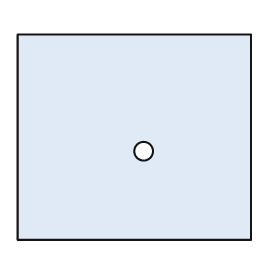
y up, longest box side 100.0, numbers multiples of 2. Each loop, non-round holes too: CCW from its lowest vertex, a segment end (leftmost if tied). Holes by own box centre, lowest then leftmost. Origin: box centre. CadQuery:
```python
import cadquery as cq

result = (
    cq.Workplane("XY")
    .moveTo(-50.0, -44.0)
    .lineTo(50.0, -44.0)
    .lineTo(50.0, 44.0)
    .lineTo(-50.0, 44.0)
    .close()
    .moveTo(4.0, -6.0)
    .circle(4.0)
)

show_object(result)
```